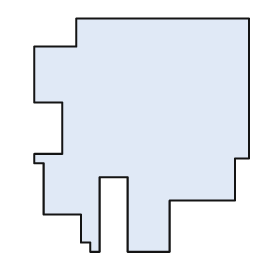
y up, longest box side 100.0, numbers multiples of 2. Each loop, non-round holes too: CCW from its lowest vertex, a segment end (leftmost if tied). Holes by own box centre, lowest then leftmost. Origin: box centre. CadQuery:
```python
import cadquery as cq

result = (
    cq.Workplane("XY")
    .moveTo(-22.0, -50.0)
    .lineTo(-18.0, -50.0)
    .lineTo(-18.0, -18.0)
    .lineTo(-6.0, -18.0)
    .lineTo(-6.0, -50.0)
    .lineTo(12.0, -50.0)
    .lineTo(12.0, -28.0)
    .lineTo(40.0, -28.0)
    .lineTo(40.0, -10.0)
    .lineTo(46.0, -10.0)
    .lineTo(46.0, 50.0)
    .lineTo(-28.0, 50.0)
    .lineTo(-28.0, 38.0)
    .lineTo(-46.0, 38.0)
    .lineTo(-46.0, 14.0)
    .lineTo(-34.0, 14.0)
    .lineTo(-34.0, -8.0)
    .lineTo(-46.0, -8.0)
    .lineTo(-46.0, -12.0)
    .lineTo(-42.0, -12.0)
    .lineTo(-42.0, -34.0)
    .lineTo(-26.0, -34.0)
    .lineTo(-26.0, -46.0)
    .lineTo(-22.0, -46.0)
    .close()
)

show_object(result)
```